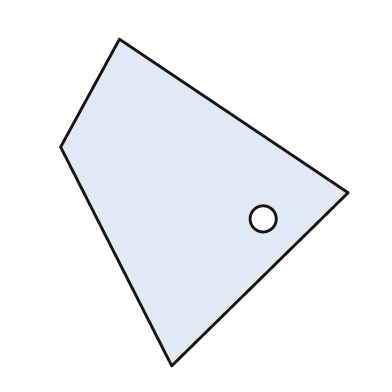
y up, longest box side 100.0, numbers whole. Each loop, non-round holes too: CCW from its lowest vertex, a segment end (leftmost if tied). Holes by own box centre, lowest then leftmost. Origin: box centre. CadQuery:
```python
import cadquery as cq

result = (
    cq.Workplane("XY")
    .moveTo(-10.0, -50.0)
    .lineTo(44.0, 3.0)
    .lineTo(-26.0, 50.0)
    .lineTo(-44.0, 17.0)
    .close()
    .moveTo(18.0, -5.0)
    .circle(4.0)
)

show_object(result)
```